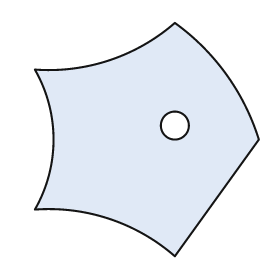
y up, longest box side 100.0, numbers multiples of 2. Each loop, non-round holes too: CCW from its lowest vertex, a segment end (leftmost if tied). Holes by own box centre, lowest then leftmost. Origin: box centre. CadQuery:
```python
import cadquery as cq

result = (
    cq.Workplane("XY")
    .moveTo(12.0, -50.0)
    .lineTo(48.0, 0.0)
    .threePointArc((34.0, 28.0), (12.0, 50.0))
    .threePointArc((-16.0, 34.0), (-48.0, 30.0))
    .threePointArc((-40.0, 0.0), (-48.0, -30.0))
    .threePointArc((-16.0, -34.0), (12.0, -50.0))
    .close()
    .moveTo(12.0, 6.0)
    .circle(6.0)
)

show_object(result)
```